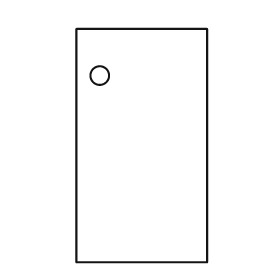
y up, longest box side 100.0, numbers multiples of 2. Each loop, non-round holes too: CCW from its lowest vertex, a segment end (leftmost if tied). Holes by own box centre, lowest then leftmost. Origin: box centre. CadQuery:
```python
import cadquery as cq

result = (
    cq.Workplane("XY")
    .moveTo(-28.0, -50.0)
    .lineTo(28.0, -50.0)
    .lineTo(28.0, 50.0)
    .lineTo(-28.0, 50.0)
    .close()
    .moveTo(-18.0, 30.0)
    .circle(4.0)
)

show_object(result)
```